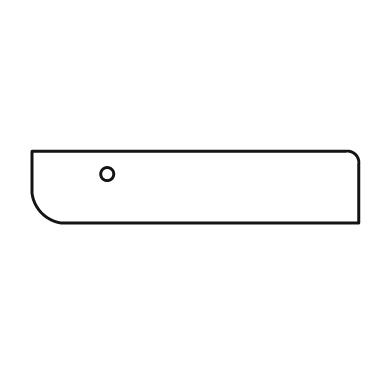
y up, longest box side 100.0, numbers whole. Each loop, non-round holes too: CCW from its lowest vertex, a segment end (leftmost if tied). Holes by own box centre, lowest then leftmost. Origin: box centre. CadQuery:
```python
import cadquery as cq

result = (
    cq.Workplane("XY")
    .moveTo(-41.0, -11.0)
    .lineTo(50.0, -11.0)
    .lineTo(50.0, 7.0)
    .threePointArc((49.0, 10.0), (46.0, 11.0))
    .lineTo(-50.0, 11.0)
    .lineTo(-50.0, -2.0)
    .threePointArc((-47.0, -8.0), (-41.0, -11.0))
    .close()
    .moveTo(-27.0, 4.0)
    .circle(2.0)
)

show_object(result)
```